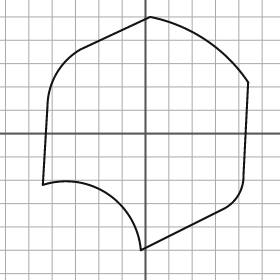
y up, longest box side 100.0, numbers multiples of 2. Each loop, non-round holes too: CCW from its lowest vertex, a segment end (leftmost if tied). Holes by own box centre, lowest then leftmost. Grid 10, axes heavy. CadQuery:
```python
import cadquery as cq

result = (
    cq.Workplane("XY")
    .moveTo(-2.0, -50.0)
    .lineTo(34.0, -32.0)
    .threePointArc((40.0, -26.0), (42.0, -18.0))
    .lineTo(44.0, 22.0)
    .threePointArc((26.0, 40.0), (2.0, 50.0))
    .lineTo(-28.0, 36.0)
    .threePointArc((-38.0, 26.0), (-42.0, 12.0))
    .lineTo(-44.0, -22.0)
    .threePointArc((-16.0, -26.0), (-2.0, -50.0))
    .close()
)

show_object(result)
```